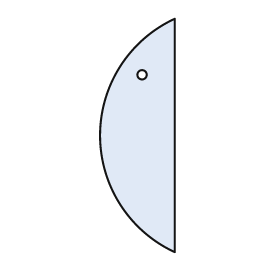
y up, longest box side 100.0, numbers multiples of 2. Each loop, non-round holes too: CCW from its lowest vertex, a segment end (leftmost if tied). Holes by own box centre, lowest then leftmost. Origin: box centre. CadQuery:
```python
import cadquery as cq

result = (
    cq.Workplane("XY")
    .moveTo(16.0, -50.0)
    .lineTo(16.0, 50.0)
    .threePointArc((-16.0, 0.0), (16.0, -50.0))
    .close()
    .moveTo(2.0, 26.0)
    .circle(2.0)
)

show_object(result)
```